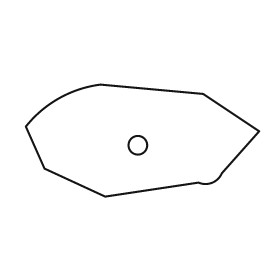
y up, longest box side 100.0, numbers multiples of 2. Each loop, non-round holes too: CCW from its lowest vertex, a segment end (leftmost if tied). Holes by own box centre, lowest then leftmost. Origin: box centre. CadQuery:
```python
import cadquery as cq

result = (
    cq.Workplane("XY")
    .moveTo(-16.0, -24.0)
    .lineTo(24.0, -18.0)
    .threePointArc((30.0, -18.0), (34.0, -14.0))
    .lineTo(50.0, 4.0)
    .lineTo(26.0, 20.0)
    .lineTo(-18.0, 24.0)
    .threePointArc((-36.0, 18.0), (-50.0, 6.0))
    .lineTo(-42.0, -12.0)
    .close()
    .moveTo(-2.0, -2.0)
    .circle(4.0)
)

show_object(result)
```